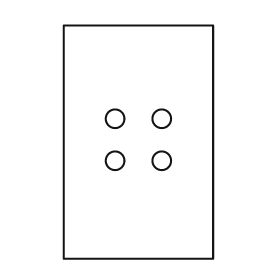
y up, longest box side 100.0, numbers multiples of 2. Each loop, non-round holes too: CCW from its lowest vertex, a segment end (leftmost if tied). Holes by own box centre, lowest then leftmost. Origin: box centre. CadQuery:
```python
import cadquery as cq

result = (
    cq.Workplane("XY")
    .moveTo(-32.0, -50.0)
    .lineTo(32.0, -50.0)
    .lineTo(32.0, 50.0)
    .lineTo(-32.0, 50.0)
    .close()
    .moveTo(-10.0, -8.0)
    .circle(4.0)
    .moveTo(10.0, -8.0)
    .circle(4.0)
    .moveTo(-10.0, 10.0)
    .circle(4.0)
    .moveTo(10.0, 10.0)
    .circle(4.0)
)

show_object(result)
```